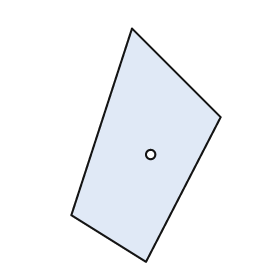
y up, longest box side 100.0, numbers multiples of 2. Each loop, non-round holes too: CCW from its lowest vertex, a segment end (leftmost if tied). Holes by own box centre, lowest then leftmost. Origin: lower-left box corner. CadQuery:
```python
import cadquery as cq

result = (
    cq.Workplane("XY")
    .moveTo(32.0, 0.0)
    .lineTo(64.0, 62.0)
    .lineTo(26.0, 100.0)
    .lineTo(0.0, 20.0)
    .close()
    .moveTo(34.0, 46.0)
    .circle(2.0)
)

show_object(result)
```